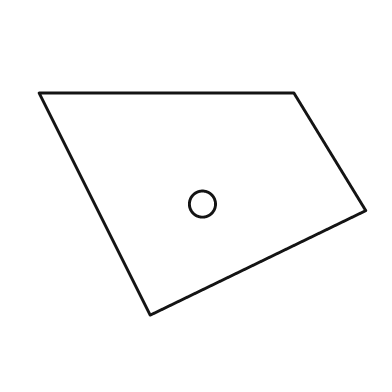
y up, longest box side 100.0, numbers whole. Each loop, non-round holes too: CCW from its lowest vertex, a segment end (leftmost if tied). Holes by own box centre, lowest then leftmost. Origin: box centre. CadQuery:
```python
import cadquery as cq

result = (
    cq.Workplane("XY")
    .moveTo(-16.0, -34.0)
    .lineTo(50.0, -2.0)
    .lineTo(28.0, 34.0)
    .lineTo(-50.0, 34.0)
    .close()
    .moveTo(0.0, 0.0)
    .circle(4.0)
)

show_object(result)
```